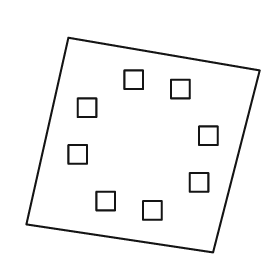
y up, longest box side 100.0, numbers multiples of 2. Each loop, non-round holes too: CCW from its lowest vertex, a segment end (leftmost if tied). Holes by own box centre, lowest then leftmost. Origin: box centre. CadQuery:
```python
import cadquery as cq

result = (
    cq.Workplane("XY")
    .moveTo(30.0, -46.0)
    .lineTo(50.0, 32.0)
    .lineTo(-32.0, 46.0)
    .lineTo(-50.0, -34.0)
    .close()
    .moveTo(0.0, -32.0)
    .lineTo(8.0, -32.0)
    .lineTo(8.0, -24.0)
    .lineTo(0.0, -24.0)
    .close()
    .moveTo(-20.0, -28.0)
    .lineTo(-12.0, -28.0)
    .lineTo(-12.0, -20.0)
    .lineTo(-20.0, -20.0)
    .close()
    .moveTo(20.0, -20.0)
    .lineTo(28.0, -20.0)
    .lineTo(28.0, -12.0)
    .lineTo(20.0, -12.0)
    .close()
    .moveTo(-32.0, -8.0)
    .lineTo(-24.0, -8.0)
    .lineTo(-24.0, 0.0)
    .lineTo(-32.0, 0.0)
    .close()
    .moveTo(24.0, 0.0)
    .lineTo(32.0, 0.0)
    .lineTo(32.0, 8.0)
    .lineTo(24.0, 8.0)
    .close()
    .moveTo(-28.0, 12.0)
    .lineTo(-20.0, 12.0)
    .lineTo(-20.0, 20.0)
    .lineTo(-28.0, 20.0)
    .close()
    .moveTo(12.0, 20.0)
    .lineTo(20.0, 20.0)
    .lineTo(20.0, 28.0)
    .lineTo(12.0, 28.0)
    .close()
    .moveTo(-8.0, 24.0)
    .lineTo(0.0, 24.0)
    .lineTo(0.0, 32.0)
    .lineTo(-8.0, 32.0)
    .close()
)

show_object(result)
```